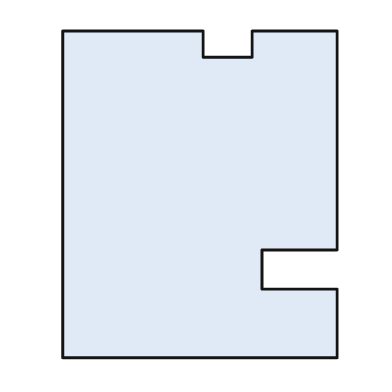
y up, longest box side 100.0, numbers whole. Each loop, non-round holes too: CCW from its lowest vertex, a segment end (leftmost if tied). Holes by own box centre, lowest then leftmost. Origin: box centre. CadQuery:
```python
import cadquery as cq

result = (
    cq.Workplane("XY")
    .moveTo(-42.0, -50.0)
    .lineTo(42.0, -50.0)
    .lineTo(42.0, -29.0)
    .lineTo(19.0, -29.0)
    .lineTo(19.0, -17.0)
    .lineTo(42.0, -17.0)
    .lineTo(42.0, 50.0)
    .lineTo(16.0, 50.0)
    .lineTo(16.0, 42.0)
    .lineTo(1.0, 42.0)
    .lineTo(1.0, 50.0)
    .lineTo(-42.0, 50.0)
    .close()
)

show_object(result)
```